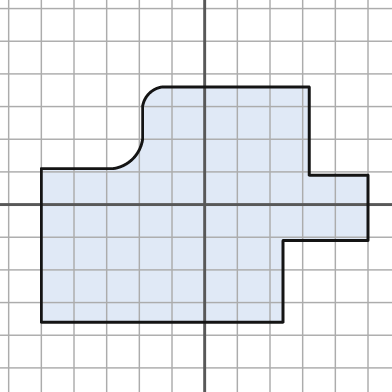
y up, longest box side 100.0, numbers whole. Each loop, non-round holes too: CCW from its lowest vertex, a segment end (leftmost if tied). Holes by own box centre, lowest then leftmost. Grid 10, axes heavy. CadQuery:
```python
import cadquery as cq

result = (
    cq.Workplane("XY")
    .moveTo(-50.0, -36.0)
    .lineTo(24.0, -36.0)
    .lineTo(24.0, -11.0)
    .lineTo(50.0, -11.0)
    .lineTo(50.0, 9.0)
    .lineTo(32.0, 9.0)
    .lineTo(32.0, 36.0)
    .lineTo(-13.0, 36.0)
    .threePointArc((-17.0, 34.0), (-19.0, 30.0))
    .lineTo(-19.0, 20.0)
    .threePointArc((-22.0, 14.0), (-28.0, 11.0))
    .lineTo(-50.0, 11.0)
    .close()
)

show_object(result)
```